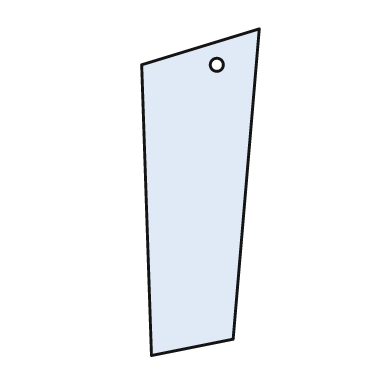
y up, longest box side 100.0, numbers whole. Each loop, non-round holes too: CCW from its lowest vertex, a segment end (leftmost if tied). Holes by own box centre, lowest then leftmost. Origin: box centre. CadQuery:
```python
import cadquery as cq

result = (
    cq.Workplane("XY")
    .moveTo(-15.0, -50.0)
    .lineTo(10.0, -45.0)
    .lineTo(18.0, 50.0)
    .lineTo(-18.0, 39.0)
    .close()
    .moveTo(5.0, 39.0)
    .circle(2.0)
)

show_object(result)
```